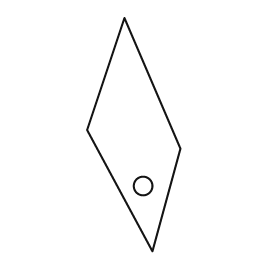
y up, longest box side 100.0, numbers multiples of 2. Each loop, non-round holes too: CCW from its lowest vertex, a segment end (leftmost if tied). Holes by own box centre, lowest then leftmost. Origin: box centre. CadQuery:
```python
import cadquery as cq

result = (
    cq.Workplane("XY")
    .moveTo(8.0, -50.0)
    .lineTo(20.0, -6.0)
    .lineTo(-4.0, 50.0)
    .lineTo(-20.0, 2.0)
    .close()
    .moveTo(4.0, -22.0)
    .circle(4.0)
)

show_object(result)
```